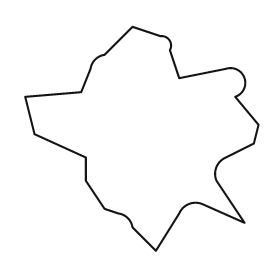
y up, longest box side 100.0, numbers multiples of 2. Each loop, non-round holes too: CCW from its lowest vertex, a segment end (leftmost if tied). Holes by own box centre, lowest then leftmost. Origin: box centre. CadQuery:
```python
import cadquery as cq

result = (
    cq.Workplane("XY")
    .moveTo(6.0, -48.0)
    .lineTo(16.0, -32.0)
    .threePointArc((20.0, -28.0), (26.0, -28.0))
    .lineTo(44.0, -36.0)
    .lineTo(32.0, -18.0)
    .threePointArc((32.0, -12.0), (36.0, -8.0))
    .lineTo(48.0, -2.0)
    .lineTo(50.0, 6.0)
    .lineTo(40.0, 18.0)
    .threePointArc((44.0, 26.0), (36.0, 30.0))
    .lineTo(16.0, 26.0)
    .lineTo(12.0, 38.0)
    .threePointArc((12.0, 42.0), (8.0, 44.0))
    .lineTo(-4.0, 48.0)
    .lineTo(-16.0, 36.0)
    .threePointArc((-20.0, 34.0), (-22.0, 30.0))
    .lineTo(-26.0, 20.0)
    .lineTo(-50.0, 18.0)
    .lineTo(-46.0, 2.0)
    .lineTo(-24.0, -8.0)
    .lineTo(-24.0, -18.0)
    .lineTo(-16.0, -30.0)
    .lineTo(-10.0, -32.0)
    .threePointArc((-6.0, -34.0), (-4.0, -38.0))
    .close()
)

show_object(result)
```